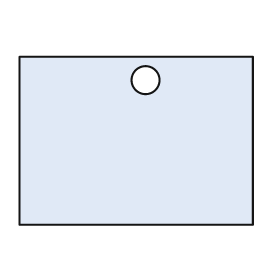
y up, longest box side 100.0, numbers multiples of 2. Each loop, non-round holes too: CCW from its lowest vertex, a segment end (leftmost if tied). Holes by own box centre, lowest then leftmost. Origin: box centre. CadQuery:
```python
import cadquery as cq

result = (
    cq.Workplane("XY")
    .moveTo(-50.0, -36.0)
    .lineTo(50.0, -36.0)
    .lineTo(50.0, 36.0)
    .lineTo(-50.0, 36.0)
    .close()
    .moveTo(4.0, 26.0)
    .circle(6.0)
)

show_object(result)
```